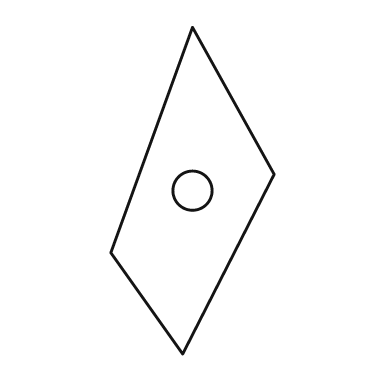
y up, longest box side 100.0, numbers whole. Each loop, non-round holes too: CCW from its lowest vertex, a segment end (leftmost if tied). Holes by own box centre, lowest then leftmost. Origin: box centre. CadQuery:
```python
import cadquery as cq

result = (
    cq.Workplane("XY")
    .moveTo(-3.0, -50.0)
    .lineTo(25.0, 5.0)
    .lineTo(0.0, 50.0)
    .lineTo(-25.0, -19.0)
    .close()
    .moveTo(0.0, 0.0)
    .circle(6.0)
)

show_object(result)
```